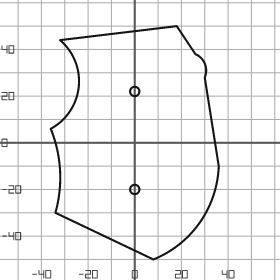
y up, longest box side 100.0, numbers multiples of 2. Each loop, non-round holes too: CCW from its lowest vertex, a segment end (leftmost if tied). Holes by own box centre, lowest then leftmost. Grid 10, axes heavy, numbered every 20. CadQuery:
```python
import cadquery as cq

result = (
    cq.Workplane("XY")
    .moveTo(8.0, -50.0)
    .threePointArc((28.0, -34.0), (36.0, -10.0))
    .lineTo(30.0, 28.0)
    .threePointArc((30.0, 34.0), (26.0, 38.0))
    .lineTo(18.0, 50.0)
    .lineTo(-32.0, 44.0)
    .threePointArc((-24.0, 24.0), (-36.0, 6.0))
    .threePointArc((-32.0, -12.0), (-34.0, -30.0))
    .close()
    .moveTo(0.0, -20.0)
    .circle(2.0)
    .moveTo(0.0, 22.0)
    .circle(2.0)
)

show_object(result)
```